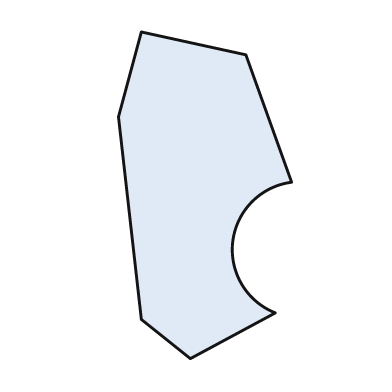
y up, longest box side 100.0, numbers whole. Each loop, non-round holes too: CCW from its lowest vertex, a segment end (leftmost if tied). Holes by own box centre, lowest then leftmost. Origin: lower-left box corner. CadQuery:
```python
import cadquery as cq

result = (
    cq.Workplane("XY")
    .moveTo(22.0, 0.0)
    .lineTo(48.0, 14.0)
    .threePointArc((35.0, 36.0), (53.0, 54.0))
    .lineTo(39.0, 93.0)
    .lineTo(7.0, 100.0)
    .lineTo(0.0, 74.0)
    .lineTo(7.0, 12.0)
    .close()
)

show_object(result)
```